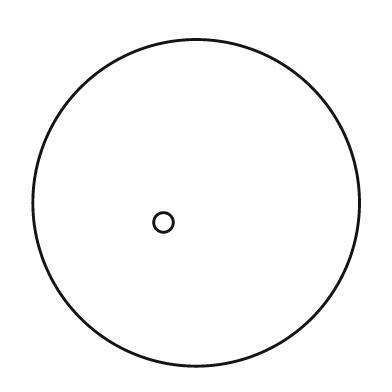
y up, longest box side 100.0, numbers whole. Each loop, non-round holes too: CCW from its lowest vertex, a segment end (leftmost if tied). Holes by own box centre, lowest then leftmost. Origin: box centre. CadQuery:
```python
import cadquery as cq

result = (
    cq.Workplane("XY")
    .moveTo(0.0, 0.0)
    .circle(50.0)
    .moveTo(-10.0, -6.0)
    .circle(3.0)
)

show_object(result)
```